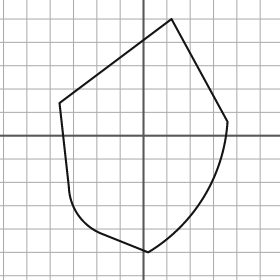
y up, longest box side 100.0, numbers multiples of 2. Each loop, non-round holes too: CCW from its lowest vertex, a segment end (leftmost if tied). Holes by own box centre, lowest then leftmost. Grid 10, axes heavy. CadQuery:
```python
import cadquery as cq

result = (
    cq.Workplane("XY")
    .moveTo(2.0, -50.0)
    .threePointArc((26.0, -26.0), (36.0, 6.0))
    .lineTo(12.0, 50.0)
    .lineTo(-36.0, 14.0)
    .lineTo(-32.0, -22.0)
    .threePointArc((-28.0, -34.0), (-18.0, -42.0))
    .close()
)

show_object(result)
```